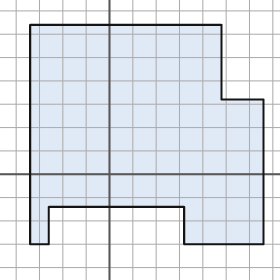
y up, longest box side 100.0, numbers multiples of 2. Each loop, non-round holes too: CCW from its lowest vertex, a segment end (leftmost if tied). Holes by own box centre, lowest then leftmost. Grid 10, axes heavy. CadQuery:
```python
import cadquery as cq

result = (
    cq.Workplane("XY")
    .moveTo(-34.0, -30.0)
    .lineTo(-26.0, -30.0)
    .lineTo(-26.0, -14.0)
    .lineTo(32.0, -14.0)
    .lineTo(32.0, -30.0)
    .lineTo(66.0, -30.0)
    .lineTo(66.0, 32.0)
    .lineTo(48.0, 32.0)
    .lineTo(48.0, 64.0)
    .lineTo(-34.0, 64.0)
    .close()
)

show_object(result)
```